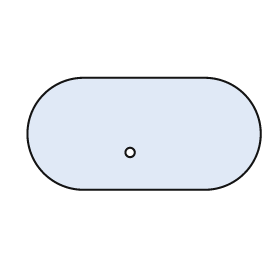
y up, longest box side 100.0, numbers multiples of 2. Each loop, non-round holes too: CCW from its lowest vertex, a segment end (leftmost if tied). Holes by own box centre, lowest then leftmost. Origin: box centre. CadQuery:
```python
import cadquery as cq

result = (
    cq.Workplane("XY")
    .moveTo(-26.0, -24.0)
    .lineTo(26.0, -24.0)
    .threePointArc((50.0, 0.0), (26.0, 24.0))
    .lineTo(-26.0, 24.0)
    .threePointArc((-50.0, 0.0), (-26.0, -24.0))
    .close()
    .moveTo(-6.0, -8.0)
    .circle(2.0)
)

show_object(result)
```